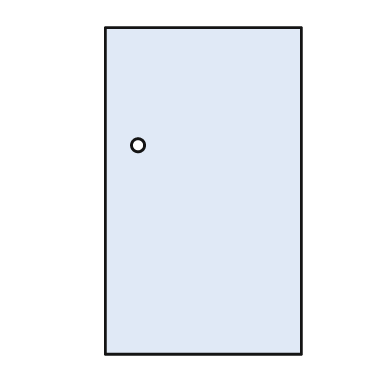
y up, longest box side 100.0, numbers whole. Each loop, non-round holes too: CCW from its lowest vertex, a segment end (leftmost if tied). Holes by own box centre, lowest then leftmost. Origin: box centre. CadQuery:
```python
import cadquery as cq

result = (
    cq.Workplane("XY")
    .moveTo(-30.0, -50.0)
    .lineTo(30.0, -50.0)
    .lineTo(30.0, 50.0)
    .lineTo(-30.0, 50.0)
    .close()
    .moveTo(-20.0, 14.0)
    .circle(2.0)
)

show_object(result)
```